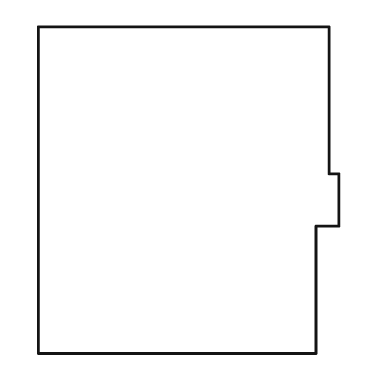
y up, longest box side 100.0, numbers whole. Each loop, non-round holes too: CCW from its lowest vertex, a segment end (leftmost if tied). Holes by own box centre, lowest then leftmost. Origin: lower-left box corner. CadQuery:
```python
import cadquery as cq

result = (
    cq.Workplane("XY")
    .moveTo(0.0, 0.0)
    .lineTo(85.0, 0.0)
    .lineTo(85.0, 39.0)
    .lineTo(92.0, 39.0)
    .lineTo(92.0, 55.0)
    .lineTo(89.0, 55.0)
    .lineTo(89.0, 100.0)
    .lineTo(0.0, 100.0)
    .close()
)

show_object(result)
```